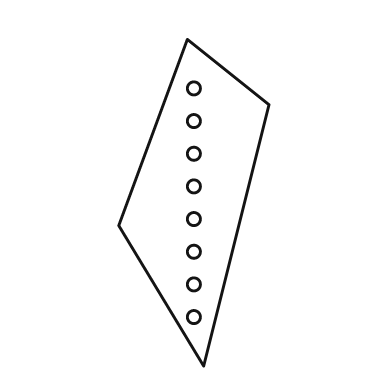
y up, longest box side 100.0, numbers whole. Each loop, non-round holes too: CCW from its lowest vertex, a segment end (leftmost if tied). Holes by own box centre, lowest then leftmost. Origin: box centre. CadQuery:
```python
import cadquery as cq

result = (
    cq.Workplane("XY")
    .moveTo(3.0, -50.0)
    .lineTo(23.0, 30.0)
    .lineTo(-2.0, 50.0)
    .lineTo(-23.0, -7.0)
    .close()
    .moveTo(0.0, -35.0)
    .circle(2.0)
    .moveTo(0.0, -25.0)
    .circle(2.0)
    .moveTo(0.0, -15.0)
    .circle(2.0)
    .moveTo(0.0, -5.0)
    .circle(2.0)
    .moveTo(0.0, 5.0)
    .circle(2.0)
    .moveTo(0.0, 15.0)
    .circle(2.0)
    .moveTo(0.0, 25.0)
    .circle(2.0)
    .moveTo(0.0, 35.0)
    .circle(2.0)
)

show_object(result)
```